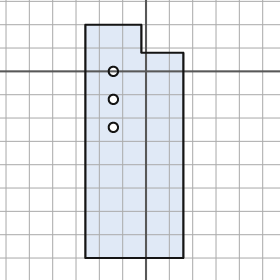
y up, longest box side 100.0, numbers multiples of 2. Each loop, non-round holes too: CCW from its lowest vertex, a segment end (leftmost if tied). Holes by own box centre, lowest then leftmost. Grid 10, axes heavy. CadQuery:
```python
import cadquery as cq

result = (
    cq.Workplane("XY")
    .moveTo(-26.0, -80.0)
    .lineTo(16.0, -80.0)
    .lineTo(16.0, 8.0)
    .lineTo(-2.0, 8.0)
    .lineTo(-2.0, 20.0)
    .lineTo(-26.0, 20.0)
    .close()
    .moveTo(-14.0, -24.0)
    .circle(2.0)
    .moveTo(-14.0, -12.0)
    .circle(2.0)
    .moveTo(-14.0, 0.0)
    .circle(2.0)
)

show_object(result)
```